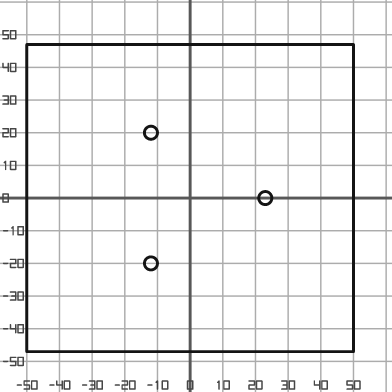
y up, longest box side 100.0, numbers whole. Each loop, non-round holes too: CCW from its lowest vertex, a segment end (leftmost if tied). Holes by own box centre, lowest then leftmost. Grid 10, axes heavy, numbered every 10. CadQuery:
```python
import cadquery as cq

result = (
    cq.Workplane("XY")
    .moveTo(-50.0, -47.0)
    .lineTo(50.0, -47.0)
    .lineTo(50.0, 47.0)
    .lineTo(-50.0, 47.0)
    .close()
    .moveTo(-12.0, -20.0)
    .circle(2.0)
    .moveTo(23.0, 0.0)
    .circle(2.0)
    .moveTo(-12.0, 20.0)
    .circle(2.0)
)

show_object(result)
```